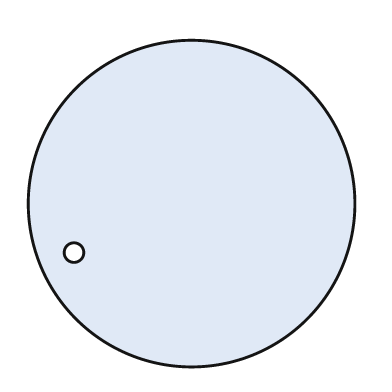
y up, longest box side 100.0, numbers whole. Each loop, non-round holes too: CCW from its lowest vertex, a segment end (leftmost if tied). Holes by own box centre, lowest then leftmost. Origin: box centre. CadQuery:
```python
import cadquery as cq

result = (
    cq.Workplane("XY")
    .moveTo(0.0, 0.0)
    .circle(50.0)
    .moveTo(-36.0, -15.0)
    .circle(3.0)
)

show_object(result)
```